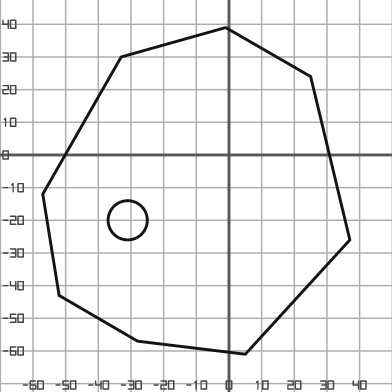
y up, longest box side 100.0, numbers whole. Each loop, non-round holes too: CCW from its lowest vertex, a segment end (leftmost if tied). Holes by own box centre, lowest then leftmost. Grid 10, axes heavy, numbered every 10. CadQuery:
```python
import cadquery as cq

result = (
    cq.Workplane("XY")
    .moveTo(5.0, -61.0)
    .lineTo(37.0, -26.0)
    .lineTo(25.0, 24.0)
    .lineTo(-1.0, 39.0)
    .lineTo(-33.0, 30.0)
    .lineTo(-57.0, -12.0)
    .lineTo(-52.0, -43.0)
    .lineTo(-28.0, -57.0)
    .close()
    .moveTo(-31.0, -20.0)
    .circle(6.0)
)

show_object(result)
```